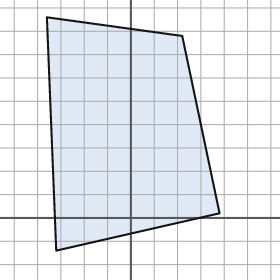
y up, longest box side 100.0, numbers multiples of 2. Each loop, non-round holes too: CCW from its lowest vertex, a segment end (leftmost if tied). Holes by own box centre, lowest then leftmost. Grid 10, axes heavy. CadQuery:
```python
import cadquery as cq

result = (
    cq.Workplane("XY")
    .moveTo(-32.0, -14.0)
    .lineTo(38.0, 2.0)
    .lineTo(22.0, 78.0)
    .lineTo(-36.0, 86.0)
    .close()
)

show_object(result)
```